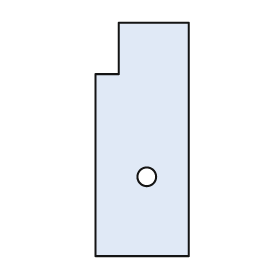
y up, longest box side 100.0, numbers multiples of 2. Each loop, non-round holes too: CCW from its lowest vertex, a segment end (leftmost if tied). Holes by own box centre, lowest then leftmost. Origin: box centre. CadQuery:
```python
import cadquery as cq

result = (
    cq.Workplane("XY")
    .moveTo(-20.0, -50.0)
    .lineTo(20.0, -50.0)
    .lineTo(20.0, 50.0)
    .lineTo(-10.0, 50.0)
    .lineTo(-10.0, 28.0)
    .lineTo(-20.0, 28.0)
    .close()
    .moveTo(2.0, -16.0)
    .circle(4.0)
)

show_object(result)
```